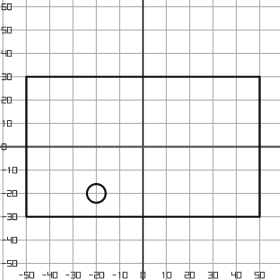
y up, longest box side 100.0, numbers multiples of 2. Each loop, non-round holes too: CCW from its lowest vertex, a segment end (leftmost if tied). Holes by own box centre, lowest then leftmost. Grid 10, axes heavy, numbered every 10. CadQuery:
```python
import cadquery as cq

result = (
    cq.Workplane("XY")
    .moveTo(-50.0, -30.0)
    .lineTo(50.0, -30.0)
    .lineTo(50.0, 30.0)
    .lineTo(-50.0, 30.0)
    .close()
    .moveTo(-20.0, -20.0)
    .circle(4.0)
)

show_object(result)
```